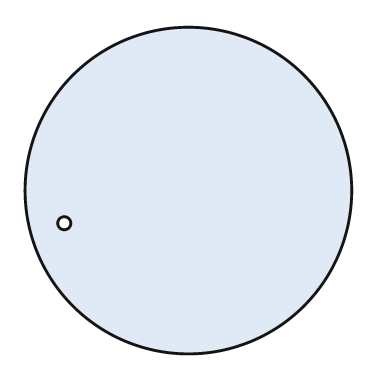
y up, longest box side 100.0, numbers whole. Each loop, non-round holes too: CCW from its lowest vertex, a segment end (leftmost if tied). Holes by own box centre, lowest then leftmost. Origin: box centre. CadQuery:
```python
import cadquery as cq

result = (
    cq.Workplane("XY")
    .moveTo(0.0, 0.0)
    .circle(50.0)
    .moveTo(-38.0, -10.0)
    .circle(2.0)
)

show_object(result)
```